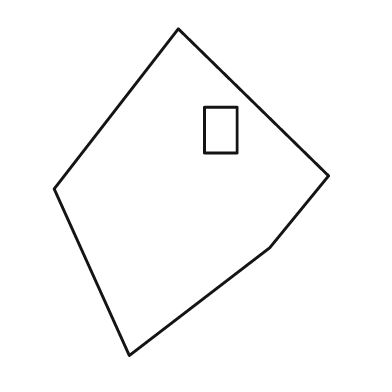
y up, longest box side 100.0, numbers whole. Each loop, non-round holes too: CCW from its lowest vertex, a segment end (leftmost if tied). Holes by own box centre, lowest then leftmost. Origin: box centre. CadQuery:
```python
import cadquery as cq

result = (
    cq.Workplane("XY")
    .moveTo(-19.0, -50.0)
    .lineTo(24.0, -17.0)
    .lineTo(42.0, 5.0)
    .lineTo(-4.0, 50.0)
    .lineTo(-42.0, 1.0)
    .close()
    .moveTo(4.0, 12.0)
    .lineTo(14.0, 12.0)
    .lineTo(14.0, 26.0)
    .lineTo(4.0, 26.0)
    .close()
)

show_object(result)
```